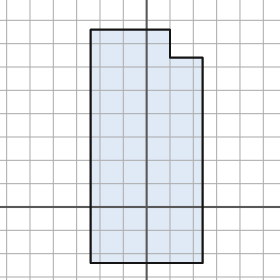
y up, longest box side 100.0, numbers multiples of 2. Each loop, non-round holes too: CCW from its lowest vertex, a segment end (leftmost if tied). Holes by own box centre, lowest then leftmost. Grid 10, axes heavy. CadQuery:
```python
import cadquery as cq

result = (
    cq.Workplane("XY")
    .moveTo(-24.0, -24.0)
    .lineTo(24.0, -24.0)
    .lineTo(24.0, 64.0)
    .lineTo(10.0, 64.0)
    .lineTo(10.0, 76.0)
    .lineTo(-24.0, 76.0)
    .close()
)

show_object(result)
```